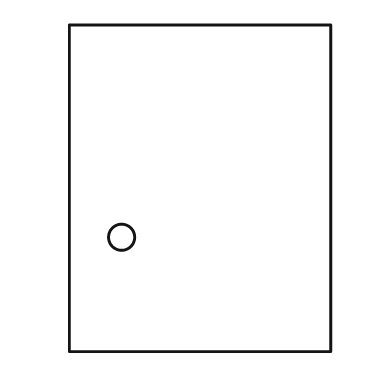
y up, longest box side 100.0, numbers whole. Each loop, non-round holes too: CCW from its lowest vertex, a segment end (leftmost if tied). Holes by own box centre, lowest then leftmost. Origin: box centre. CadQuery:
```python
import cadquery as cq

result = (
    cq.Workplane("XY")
    .moveTo(-40.0, -50.0)
    .lineTo(40.0, -50.0)
    .lineTo(40.0, 50.0)
    .lineTo(-40.0, 50.0)
    .close()
    .moveTo(-24.0, -15.0)
    .circle(4.0)
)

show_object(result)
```